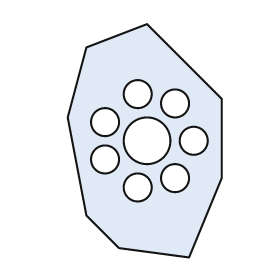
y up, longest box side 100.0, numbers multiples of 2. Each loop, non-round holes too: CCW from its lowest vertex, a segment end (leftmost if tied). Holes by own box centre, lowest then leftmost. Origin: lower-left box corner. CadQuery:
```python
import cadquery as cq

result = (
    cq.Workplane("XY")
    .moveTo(52.0, 0.0)
    .lineTo(66.0, 34.0)
    .lineTo(66.0, 68.0)
    .lineTo(34.0, 100.0)
    .lineTo(8.0, 90.0)
    .lineTo(0.0, 60.0)
    .lineTo(8.0, 18.0)
    .lineTo(22.0, 4.0)
    .close()
    .moveTo(30.0, 30.0)
    .circle(6.0)
    .moveTo(46.0, 34.0)
    .circle(6.0)
    .moveTo(16.0, 42.0)
    .circle(6.0)
    .moveTo(34.0, 50.0)
    .circle(10.0)
    .moveTo(54.0, 50.0)
    .circle(6.0)
    .moveTo(16.0, 58.0)
    .circle(6.0)
    .moveTo(46.0, 66.0)
    .circle(6.0)
    .moveTo(30.0, 70.0)
    .circle(6.0)
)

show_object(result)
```